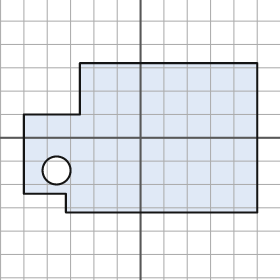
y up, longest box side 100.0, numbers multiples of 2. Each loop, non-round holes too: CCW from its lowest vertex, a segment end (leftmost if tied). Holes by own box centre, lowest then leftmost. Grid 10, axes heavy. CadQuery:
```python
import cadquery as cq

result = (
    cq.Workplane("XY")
    .moveTo(-32.0, -32.0)
    .lineTo(50.0, -32.0)
    .lineTo(50.0, 32.0)
    .lineTo(-26.0, 32.0)
    .lineTo(-26.0, 10.0)
    .lineTo(-50.0, 10.0)
    .lineTo(-50.0, -24.0)
    .lineTo(-32.0, -24.0)
    .close()
    .moveTo(-36.0, -14.0)
    .circle(6.0)
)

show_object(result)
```